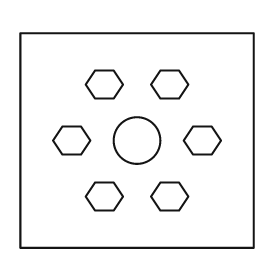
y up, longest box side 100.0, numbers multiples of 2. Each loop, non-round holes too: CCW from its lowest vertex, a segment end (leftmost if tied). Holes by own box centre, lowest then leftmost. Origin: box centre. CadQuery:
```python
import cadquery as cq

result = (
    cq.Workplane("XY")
    .moveTo(-50.0, -46.0)
    .lineTo(50.0, -46.0)
    .lineTo(50.0, 46.0)
    .lineTo(-50.0, 46.0)
    .close()
    .moveTo(-18.0, -30.0)
    .lineTo(-10.0, -30.0)
    .lineTo(-6.0, -24.0)
    .lineTo(-10.0, -18.0)
    .lineTo(-18.0, -18.0)
    .lineTo(-22.0, -24.0)
    .close()
    .moveTo(10.0, -30.0)
    .lineTo(18.0, -30.0)
    .lineTo(22.0, -24.0)
    .lineTo(18.0, -18.0)
    .lineTo(10.0, -18.0)
    .lineTo(6.0, -24.0)
    .close()
    .moveTo(-32.0, -6.0)
    .lineTo(-24.0, -6.0)
    .lineTo(-20.0, 0.0)
    .lineTo(-24.0, 6.0)
    .lineTo(-32.0, 6.0)
    .lineTo(-36.0, 0.0)
    .close()
    .moveTo(0.0, 0.0)
    .circle(10.0)
    .moveTo(24.0, -6.0)
    .lineTo(32.0, -6.0)
    .lineTo(36.0, 0.0)
    .lineTo(32.0, 6.0)
    .lineTo(24.0, 6.0)
    .lineTo(20.0, 0.0)
    .close()
    .moveTo(-18.0, 18.0)
    .lineTo(-10.0, 18.0)
    .lineTo(-6.0, 24.0)
    .lineTo(-10.0, 30.0)
    .lineTo(-18.0, 30.0)
    .lineTo(-22.0, 24.0)
    .close()
    .moveTo(10.0, 18.0)
    .lineTo(18.0, 18.0)
    .lineTo(22.0, 24.0)
    .lineTo(18.0, 30.0)
    .lineTo(10.0, 30.0)
    .lineTo(6.0, 24.0)
    .close()
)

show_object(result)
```